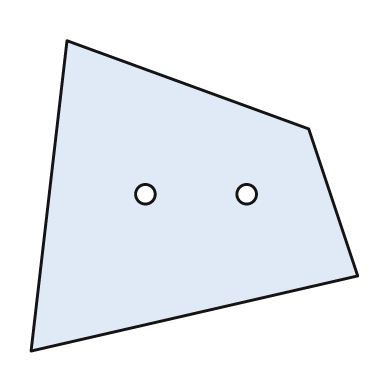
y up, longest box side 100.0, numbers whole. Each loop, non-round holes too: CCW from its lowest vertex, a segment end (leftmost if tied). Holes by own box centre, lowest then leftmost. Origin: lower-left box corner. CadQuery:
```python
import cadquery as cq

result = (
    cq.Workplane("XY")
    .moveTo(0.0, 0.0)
    .lineTo(100.0, 23.0)
    .lineTo(85.0, 68.0)
    .lineTo(11.0, 95.0)
    .close()
    .moveTo(35.0, 48.0)
    .circle(3.0)
    .moveTo(66.0, 48.0)
    .circle(3.0)
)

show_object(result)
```